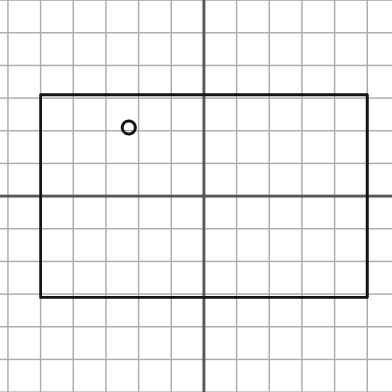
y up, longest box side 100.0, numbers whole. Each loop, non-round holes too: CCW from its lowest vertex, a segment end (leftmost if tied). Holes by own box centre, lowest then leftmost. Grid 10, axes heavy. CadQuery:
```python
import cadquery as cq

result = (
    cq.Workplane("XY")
    .moveTo(-50.0, -31.0)
    .lineTo(50.0, -31.0)
    .lineTo(50.0, 31.0)
    .lineTo(-50.0, 31.0)
    .close()
    .moveTo(-23.0, 21.0)
    .circle(2.0)
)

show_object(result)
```